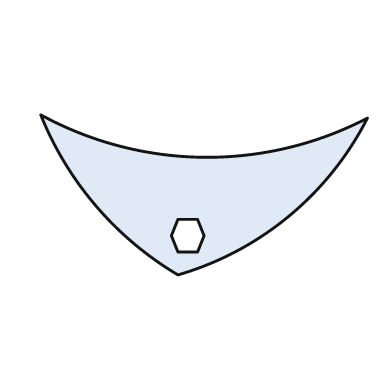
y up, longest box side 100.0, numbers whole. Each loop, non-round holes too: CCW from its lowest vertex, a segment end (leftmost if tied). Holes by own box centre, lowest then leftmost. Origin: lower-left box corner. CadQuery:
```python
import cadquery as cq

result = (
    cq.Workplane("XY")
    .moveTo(42.0, 0.0)
    .threePointArc((76.0, 18.0), (100.0, 48.0))
    .threePointArc((50.0, 36.0), (0.0, 49.0))
    .threePointArc((17.0, 21.0), (42.0, 0.0))
    .close()
    .moveTo(42.0, 7.0)
    .lineTo(48.0, 7.0)
    .lineTo(50.0, 12.0)
    .lineTo(48.0, 17.0)
    .lineTo(42.0, 17.0)
    .lineTo(40.0, 12.0)
    .close()
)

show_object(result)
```